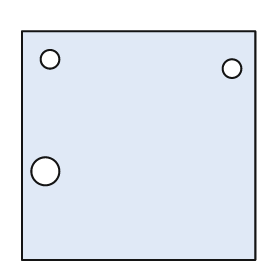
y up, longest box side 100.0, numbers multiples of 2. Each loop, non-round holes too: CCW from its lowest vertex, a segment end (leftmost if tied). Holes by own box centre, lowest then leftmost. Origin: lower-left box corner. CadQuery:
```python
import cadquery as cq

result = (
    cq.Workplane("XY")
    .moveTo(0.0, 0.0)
    .lineTo(100.0, 0.0)
    .lineTo(100.0, 98.0)
    .lineTo(0.0, 98.0)
    .close()
    .moveTo(10.0, 38.0)
    .circle(6.0)
    .moveTo(90.0, 82.0)
    .circle(4.0)
    .moveTo(12.0, 86.0)
    .circle(4.0)
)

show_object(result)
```